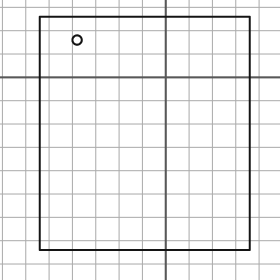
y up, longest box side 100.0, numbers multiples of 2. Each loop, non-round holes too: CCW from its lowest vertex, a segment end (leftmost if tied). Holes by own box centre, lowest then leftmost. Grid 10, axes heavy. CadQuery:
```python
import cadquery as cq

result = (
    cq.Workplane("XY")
    .moveTo(-54.0, -74.0)
    .lineTo(36.0, -74.0)
    .lineTo(36.0, 26.0)
    .lineTo(-54.0, 26.0)
    .close()
    .moveTo(-38.0, 16.0)
    .circle(2.0)
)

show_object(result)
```